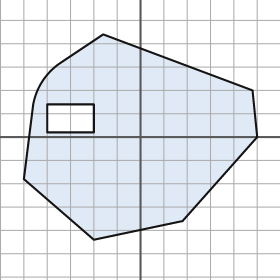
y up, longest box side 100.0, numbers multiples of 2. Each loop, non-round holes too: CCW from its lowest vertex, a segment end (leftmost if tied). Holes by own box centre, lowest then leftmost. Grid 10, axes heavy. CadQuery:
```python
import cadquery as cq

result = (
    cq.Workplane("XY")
    .moveTo(-20.0, -44.0)
    .lineTo(18.0, -36.0)
    .lineTo(50.0, 0.0)
    .lineTo(48.0, 20.0)
    .lineTo(-16.0, 44.0)
    .lineTo(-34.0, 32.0)
    .threePointArc((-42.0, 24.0), (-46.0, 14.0))
    .lineTo(-50.0, -18.0)
    .close()
    .moveTo(-40.0, 2.0)
    .lineTo(-20.0, 2.0)
    .lineTo(-20.0, 14.0)
    .lineTo(-40.0, 14.0)
    .close()
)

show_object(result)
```